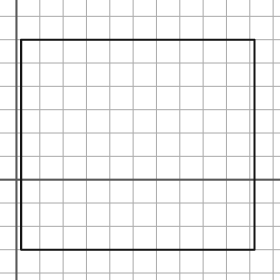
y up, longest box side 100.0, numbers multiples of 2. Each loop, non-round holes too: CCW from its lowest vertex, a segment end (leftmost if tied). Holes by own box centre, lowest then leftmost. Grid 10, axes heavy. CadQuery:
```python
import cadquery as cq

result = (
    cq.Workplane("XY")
    .moveTo(2.0, -30.0)
    .lineTo(102.0, -30.0)
    .lineTo(102.0, 60.0)
    .lineTo(2.0, 60.0)
    .close()
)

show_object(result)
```